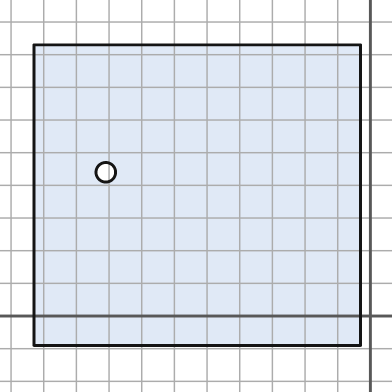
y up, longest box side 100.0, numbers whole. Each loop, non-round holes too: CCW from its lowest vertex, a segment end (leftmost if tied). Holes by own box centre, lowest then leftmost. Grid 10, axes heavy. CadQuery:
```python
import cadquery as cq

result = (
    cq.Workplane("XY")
    .moveTo(-103.0, -9.0)
    .lineTo(-3.0, -9.0)
    .lineTo(-3.0, 83.0)
    .lineTo(-103.0, 83.0)
    .close()
    .moveTo(-81.0, 44.0)
    .circle(3.0)
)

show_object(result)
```